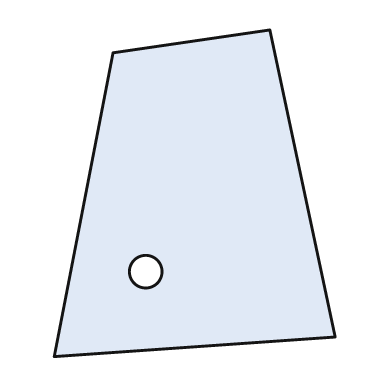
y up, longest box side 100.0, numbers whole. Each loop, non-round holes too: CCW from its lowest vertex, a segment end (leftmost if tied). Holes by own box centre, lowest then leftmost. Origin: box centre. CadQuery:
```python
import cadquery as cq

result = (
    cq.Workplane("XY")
    .moveTo(-43.0, -50.0)
    .lineTo(43.0, -44.0)
    .lineTo(23.0, 50.0)
    .lineTo(-25.0, 43.0)
    .close()
    .moveTo(-15.0, -24.0)
    .circle(5.0)
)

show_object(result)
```